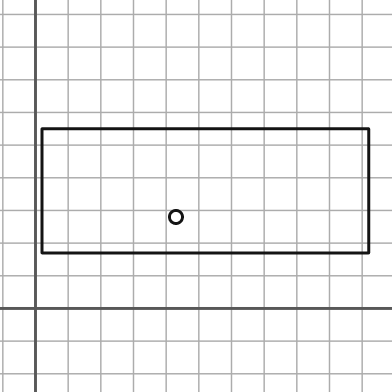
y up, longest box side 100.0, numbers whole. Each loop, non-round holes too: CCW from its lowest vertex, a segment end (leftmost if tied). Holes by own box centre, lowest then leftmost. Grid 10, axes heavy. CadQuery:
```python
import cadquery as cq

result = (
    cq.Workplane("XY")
    .moveTo(2.0, 17.0)
    .lineTo(102.0, 17.0)
    .lineTo(102.0, 55.0)
    .lineTo(2.0, 55.0)
    .close()
    .moveTo(43.0, 28.0)
    .circle(2.0)
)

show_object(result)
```